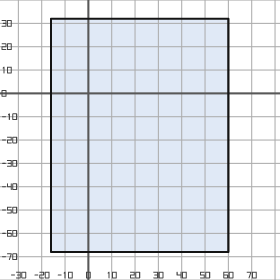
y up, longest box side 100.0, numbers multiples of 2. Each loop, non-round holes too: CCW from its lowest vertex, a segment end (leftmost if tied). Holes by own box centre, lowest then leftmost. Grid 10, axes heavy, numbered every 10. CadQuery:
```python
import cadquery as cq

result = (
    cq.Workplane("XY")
    .moveTo(-16.0, -68.0)
    .lineTo(60.0, -68.0)
    .lineTo(60.0, 32.0)
    .lineTo(-16.0, 32.0)
    .close()
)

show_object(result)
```